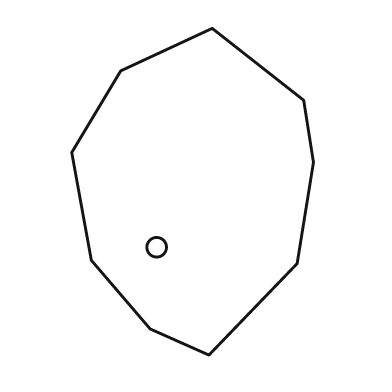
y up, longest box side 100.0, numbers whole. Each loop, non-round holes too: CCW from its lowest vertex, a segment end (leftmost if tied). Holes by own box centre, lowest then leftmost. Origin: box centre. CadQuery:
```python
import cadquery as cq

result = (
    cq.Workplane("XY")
    .moveTo(5.0, -50.0)
    .lineTo(32.0, -22.0)
    .lineTo(37.0, 9.0)
    .lineTo(34.0, 28.0)
    .lineTo(6.0, 50.0)
    .lineTo(-22.0, 37.0)
    .lineTo(-37.0, 12.0)
    .lineTo(-31.0, -21.0)
    .lineTo(-13.0, -42.0)
    .close()
    .moveTo(-11.0, -17.0)
    .circle(3.0)
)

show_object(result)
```